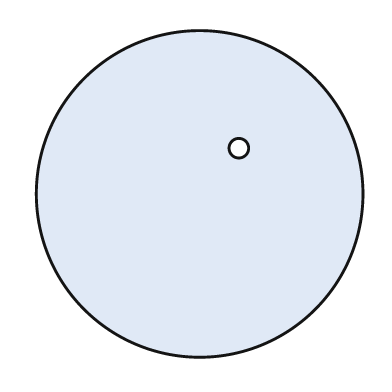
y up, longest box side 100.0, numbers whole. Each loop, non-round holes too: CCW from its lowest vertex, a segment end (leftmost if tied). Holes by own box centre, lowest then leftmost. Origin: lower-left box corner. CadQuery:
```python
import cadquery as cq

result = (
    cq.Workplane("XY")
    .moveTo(50.0, 50.0)
    .circle(50.0)
    .moveTo(62.0, 64.0)
    .circle(3.0)
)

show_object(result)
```